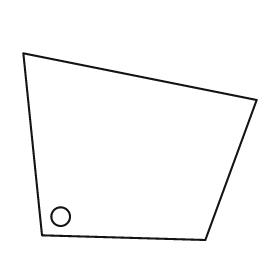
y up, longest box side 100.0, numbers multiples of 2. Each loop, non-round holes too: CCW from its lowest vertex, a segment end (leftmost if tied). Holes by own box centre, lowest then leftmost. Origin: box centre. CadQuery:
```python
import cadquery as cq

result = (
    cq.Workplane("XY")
    .moveTo(28.0, -40.0)
    .lineTo(50.0, 20.0)
    .lineTo(-50.0, 40.0)
    .lineTo(-42.0, -38.0)
    .close()
    .moveTo(-34.0, -30.0)
    .circle(4.0)
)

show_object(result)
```